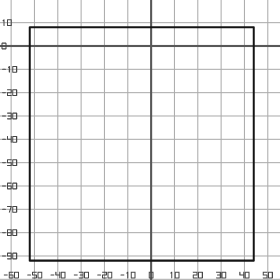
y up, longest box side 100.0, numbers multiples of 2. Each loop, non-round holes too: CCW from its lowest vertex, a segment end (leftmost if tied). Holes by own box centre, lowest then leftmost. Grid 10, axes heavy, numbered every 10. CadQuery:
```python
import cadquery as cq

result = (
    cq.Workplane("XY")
    .moveTo(-52.0, -92.0)
    .lineTo(44.0, -92.0)
    .lineTo(44.0, 8.0)
    .lineTo(-52.0, 8.0)
    .close()
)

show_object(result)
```